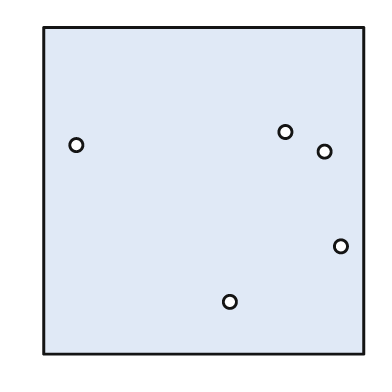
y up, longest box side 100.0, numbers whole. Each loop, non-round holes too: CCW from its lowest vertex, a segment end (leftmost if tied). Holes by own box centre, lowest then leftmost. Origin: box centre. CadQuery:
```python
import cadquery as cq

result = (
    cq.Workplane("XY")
    .moveTo(-49.0, -50.0)
    .lineTo(49.0, -50.0)
    .lineTo(49.0, 50.0)
    .lineTo(-49.0, 50.0)
    .close()
    .moveTo(8.0, -34.0)
    .circle(2.0)
    .moveTo(42.0, -17.0)
    .circle(2.0)
    .moveTo(37.0, 12.0)
    .circle(2.0)
    .moveTo(-39.0, 14.0)
    .circle(2.0)
    .moveTo(25.0, 18.0)
    .circle(2.0)
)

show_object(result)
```